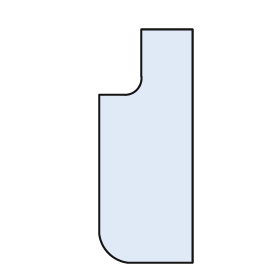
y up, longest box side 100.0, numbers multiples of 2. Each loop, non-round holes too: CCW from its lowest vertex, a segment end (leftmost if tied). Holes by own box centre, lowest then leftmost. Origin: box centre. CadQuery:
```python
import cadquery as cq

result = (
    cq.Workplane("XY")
    .moveTo(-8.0, -50.0)
    .lineTo(20.0, -50.0)
    .lineTo(20.0, 50.0)
    .lineTo(-2.0, 50.0)
    .lineTo(-2.0, 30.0)
    .threePointArc((-4.0, 24.0), (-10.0, 22.0))
    .lineTo(-20.0, 22.0)
    .lineTo(-20.0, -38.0)
    .threePointArc((-16.0, -46.0), (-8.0, -50.0))
    .close()
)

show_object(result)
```